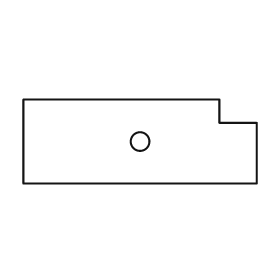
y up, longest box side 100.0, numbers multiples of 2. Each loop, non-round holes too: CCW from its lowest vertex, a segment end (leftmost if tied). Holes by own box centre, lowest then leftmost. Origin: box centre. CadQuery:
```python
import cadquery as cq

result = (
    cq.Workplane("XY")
    .moveTo(-50.0, -18.0)
    .lineTo(50.0, -18.0)
    .lineTo(50.0, 8.0)
    .lineTo(34.0, 8.0)
    .lineTo(34.0, 18.0)
    .lineTo(-50.0, 18.0)
    .close()
    .moveTo(0.0, 0.0)
    .circle(4.0)
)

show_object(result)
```